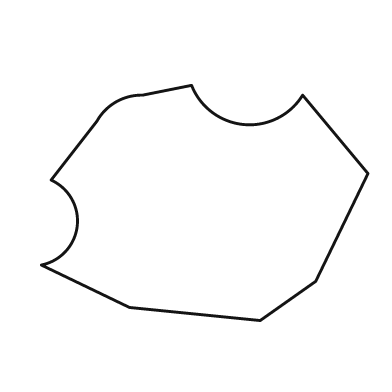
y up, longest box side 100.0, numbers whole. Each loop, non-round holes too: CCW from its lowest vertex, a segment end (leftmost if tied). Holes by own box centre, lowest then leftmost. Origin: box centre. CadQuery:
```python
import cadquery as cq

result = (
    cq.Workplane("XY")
    .moveTo(17.0, -36.0)
    .lineTo(34.0, -24.0)
    .lineTo(50.0, 9.0)
    .lineTo(30.0, 33.0)
    .threePointArc((12.0, 24.0), (-4.0, 36.0))
    .lineTo(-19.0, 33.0)
    .threePointArc((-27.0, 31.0), (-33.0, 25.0))
    .lineTo(-47.0, 7.0)
    .threePointArc((-39.0, -7.0), (-50.0, -19.0))
    .lineTo(-23.0, -32.0)
    .close()
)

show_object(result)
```